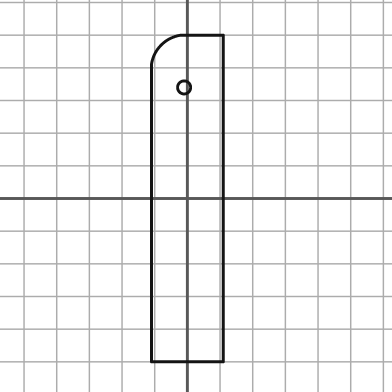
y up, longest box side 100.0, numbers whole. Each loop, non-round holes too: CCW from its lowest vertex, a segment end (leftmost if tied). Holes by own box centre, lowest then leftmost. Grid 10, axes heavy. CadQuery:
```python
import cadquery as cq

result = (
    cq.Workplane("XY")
    .moveTo(-11.0, -50.0)
    .lineTo(11.0, -50.0)
    .lineTo(11.0, 50.0)
    .lineTo(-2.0, 50.0)
    .threePointArc((-8.0, 47.0), (-11.0, 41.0))
    .close()
    .moveTo(-1.0, 34.0)
    .circle(2.0)
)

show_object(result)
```